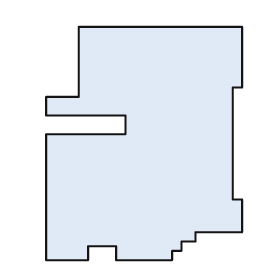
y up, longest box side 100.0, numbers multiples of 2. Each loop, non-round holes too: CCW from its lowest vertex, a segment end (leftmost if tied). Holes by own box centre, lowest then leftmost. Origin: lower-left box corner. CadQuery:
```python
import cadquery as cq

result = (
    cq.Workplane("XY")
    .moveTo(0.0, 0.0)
    .lineTo(18.0, 0.0)
    .lineTo(18.0, 6.0)
    .lineTo(30.0, 6.0)
    .lineTo(30.0, 0.0)
    .lineTo(54.0, 0.0)
    .lineTo(54.0, 4.0)
    .lineTo(58.0, 4.0)
    .lineTo(58.0, 8.0)
    .lineTo(64.0, 8.0)
    .lineTo(64.0, 12.0)
    .lineTo(84.0, 12.0)
    .lineTo(84.0, 26.0)
    .lineTo(80.0, 26.0)
    .lineTo(80.0, 74.0)
    .lineTo(84.0, 74.0)
    .lineTo(84.0, 100.0)
    .lineTo(14.0, 100.0)
    .lineTo(14.0, 70.0)
    .lineTo(0.0, 70.0)
    .lineTo(0.0, 62.0)
    .lineTo(34.0, 62.0)
    .lineTo(34.0, 54.0)
    .lineTo(0.0, 54.0)
    .close()
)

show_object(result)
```